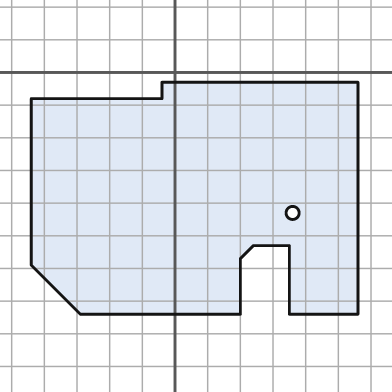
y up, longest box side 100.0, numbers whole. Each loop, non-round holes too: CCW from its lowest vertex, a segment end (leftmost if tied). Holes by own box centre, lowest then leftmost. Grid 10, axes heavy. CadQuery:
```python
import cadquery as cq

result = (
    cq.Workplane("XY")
    .moveTo(-29.0, -74.0)
    .lineTo(20.0, -74.0)
    .lineTo(20.0, -57.0)
    .lineTo(24.0, -53.0)
    .lineTo(35.0, -53.0)
    .lineTo(35.0, -74.0)
    .lineTo(56.0, -74.0)
    .lineTo(56.0, -3.0)
    .lineTo(-4.0, -3.0)
    .lineTo(-4.0, -8.0)
    .lineTo(-44.0, -8.0)
    .lineTo(-44.0, -59.0)
    .close()
    .moveTo(36.0, -43.0)
    .circle(2.0)
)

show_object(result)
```